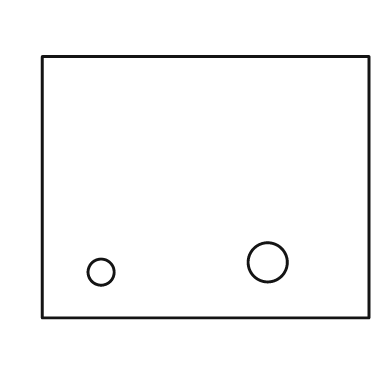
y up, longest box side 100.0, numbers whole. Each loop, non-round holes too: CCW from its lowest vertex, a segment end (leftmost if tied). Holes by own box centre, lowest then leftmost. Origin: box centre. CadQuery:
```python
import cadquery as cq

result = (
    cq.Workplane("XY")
    .moveTo(-50.0, -40.0)
    .lineTo(50.0, -40.0)
    .lineTo(50.0, 40.0)
    .lineTo(-50.0, 40.0)
    .close()
    .moveTo(-32.0, -26.0)
    .circle(4.0)
    .moveTo(19.0, -23.0)
    .circle(6.0)
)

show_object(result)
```